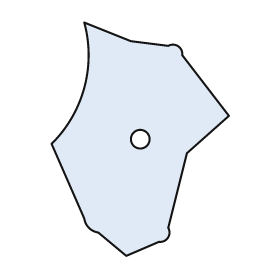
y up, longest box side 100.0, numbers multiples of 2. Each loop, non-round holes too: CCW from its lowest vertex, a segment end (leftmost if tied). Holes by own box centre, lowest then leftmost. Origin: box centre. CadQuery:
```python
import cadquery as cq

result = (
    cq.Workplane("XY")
    .moveTo(-6.0, -50.0)
    .lineTo(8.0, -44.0)
    .threePointArc((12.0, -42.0), (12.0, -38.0))
    .lineTo(20.0, -6.0)
    .lineTo(38.0, 10.0)
    .lineTo(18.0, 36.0)
    .threePointArc((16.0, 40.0), (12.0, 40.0))
    .lineTo(-4.0, 42.0)
    .lineTo(-24.0, 50.0)
    .threePointArc((-24.0, 22.0), (-38.0, -2.0))
    .lineTo(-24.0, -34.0)
    .threePointArc((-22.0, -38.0), (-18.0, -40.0))
    .close()
    .moveTo(0.0, 0.0)
    .circle(4.0)
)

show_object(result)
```